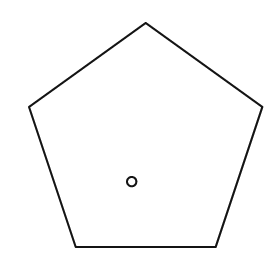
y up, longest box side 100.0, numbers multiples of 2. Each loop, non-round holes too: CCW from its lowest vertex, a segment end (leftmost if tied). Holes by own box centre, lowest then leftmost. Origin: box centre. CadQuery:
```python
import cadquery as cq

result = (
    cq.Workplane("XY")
    .moveTo(-30.0, -48.0)
    .lineTo(30.0, -48.0)
    .lineTo(50.0, 12.0)
    .lineTo(0.0, 48.0)
    .lineTo(-50.0, 12.0)
    .close()
    .moveTo(-6.0, -20.0)
    .circle(2.0)
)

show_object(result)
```